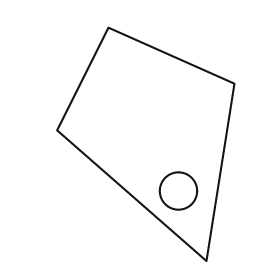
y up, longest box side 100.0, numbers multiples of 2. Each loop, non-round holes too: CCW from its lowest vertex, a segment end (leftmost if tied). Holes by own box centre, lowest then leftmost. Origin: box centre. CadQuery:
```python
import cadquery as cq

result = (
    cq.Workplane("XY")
    .moveTo(26.0, -50.0)
    .lineTo(38.0, 26.0)
    .lineTo(-16.0, 50.0)
    .lineTo(-38.0, 6.0)
    .close()
    .moveTo(14.0, -20.0)
    .circle(8.0)
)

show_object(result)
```